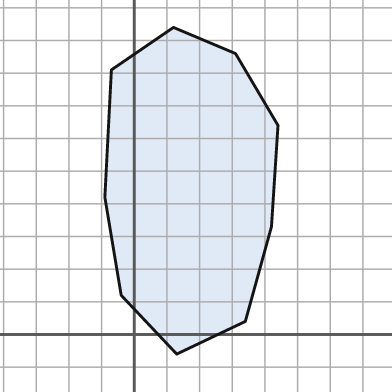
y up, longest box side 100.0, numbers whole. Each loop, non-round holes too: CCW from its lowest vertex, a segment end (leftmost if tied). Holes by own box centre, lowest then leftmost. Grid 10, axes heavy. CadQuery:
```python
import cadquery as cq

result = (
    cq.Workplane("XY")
    .moveTo(13.0, -6.0)
    .lineTo(34.0, 4.0)
    .lineTo(42.0, 33.0)
    .lineTo(44.0, 64.0)
    .lineTo(31.0, 86.0)
    .lineTo(12.0, 94.0)
    .lineTo(-7.0, 81.0)
    .lineTo(-9.0, 42.0)
    .lineTo(-4.0, 12.0)
    .close()
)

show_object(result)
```